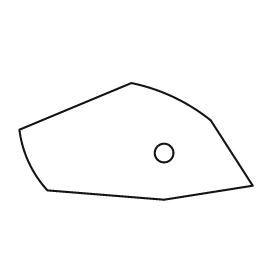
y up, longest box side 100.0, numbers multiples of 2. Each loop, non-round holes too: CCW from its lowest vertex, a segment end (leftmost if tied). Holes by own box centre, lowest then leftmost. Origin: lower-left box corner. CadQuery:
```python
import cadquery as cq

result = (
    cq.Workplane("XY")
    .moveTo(62.0, 0.0)
    .lineTo(100.0, 6.0)
    .lineTo(82.0, 34.0)
    .threePointArc((66.0, 44.0), (48.0, 50.0))
    .lineTo(0.0, 30.0)
    .threePointArc((4.0, 16.0), (12.0, 4.0))
    .close()
    .moveTo(62.0, 20.0)
    .circle(4.0)
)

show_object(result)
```